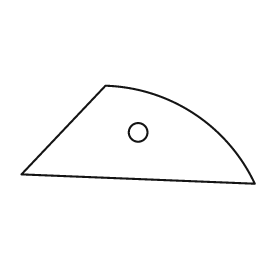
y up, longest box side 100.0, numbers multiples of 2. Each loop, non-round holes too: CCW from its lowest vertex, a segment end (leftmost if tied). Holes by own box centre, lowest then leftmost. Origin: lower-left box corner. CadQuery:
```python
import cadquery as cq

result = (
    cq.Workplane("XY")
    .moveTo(100.0, 0.0)
    .threePointArc((74.0, 30.0), (36.0, 42.0))
    .lineTo(0.0, 4.0)
    .close()
    .moveTo(50.0, 22.0)
    .circle(4.0)
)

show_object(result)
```